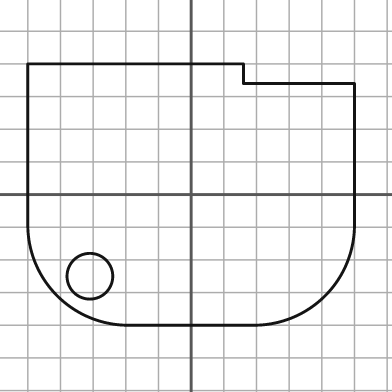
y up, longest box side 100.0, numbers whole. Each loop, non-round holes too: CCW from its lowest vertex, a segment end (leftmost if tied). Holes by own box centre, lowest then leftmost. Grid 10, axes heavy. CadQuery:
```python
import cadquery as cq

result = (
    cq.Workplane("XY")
    .moveTo(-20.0, -40.0)
    .lineTo(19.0, -40.0)
    .threePointArc((41.0, -31.0), (50.0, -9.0))
    .lineTo(50.0, 34.0)
    .lineTo(16.0, 34.0)
    .lineTo(16.0, 40.0)
    .lineTo(-50.0, 40.0)
    .lineTo(-50.0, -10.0)
    .threePointArc((-41.0, -31.0), (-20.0, -40.0))
    .close()
    .moveTo(-31.0, -25.0)
    .circle(7.0)
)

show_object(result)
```